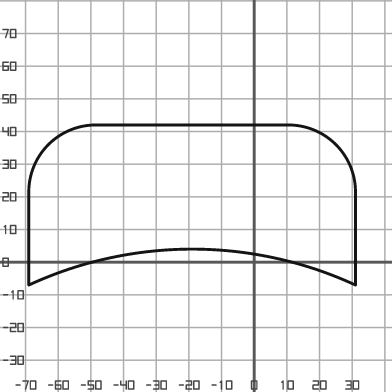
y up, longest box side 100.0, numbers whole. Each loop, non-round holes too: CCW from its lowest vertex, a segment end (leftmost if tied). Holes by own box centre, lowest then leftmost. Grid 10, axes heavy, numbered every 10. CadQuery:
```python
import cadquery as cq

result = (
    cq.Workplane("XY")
    .moveTo(-69.0, -7.0)
    .threePointArc((-19.0, 4.0), (31.0, -7.0))
    .lineTo(31.0, 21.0)
    .threePointArc((25.0, 36.0), (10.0, 42.0))
    .lineTo(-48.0, 42.0)
    .threePointArc((-63.0, 36.0), (-69.0, 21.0))
    .close()
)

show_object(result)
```